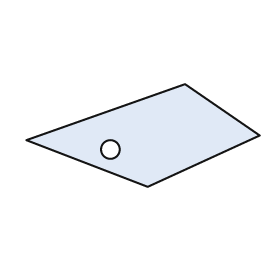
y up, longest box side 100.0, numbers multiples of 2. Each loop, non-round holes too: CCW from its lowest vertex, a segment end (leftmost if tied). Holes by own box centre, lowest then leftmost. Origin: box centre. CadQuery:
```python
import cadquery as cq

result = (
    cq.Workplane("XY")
    .moveTo(2.0, -22.0)
    .lineTo(50.0, 0.0)
    .lineTo(18.0, 22.0)
    .lineTo(-50.0, -2.0)
    .close()
    .moveTo(-14.0, -6.0)
    .circle(4.0)
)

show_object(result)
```